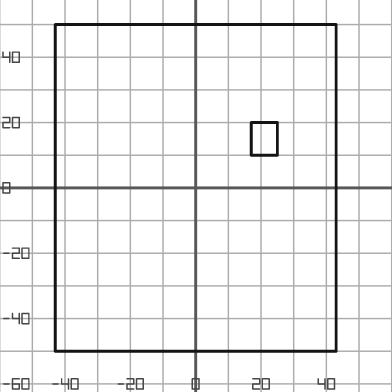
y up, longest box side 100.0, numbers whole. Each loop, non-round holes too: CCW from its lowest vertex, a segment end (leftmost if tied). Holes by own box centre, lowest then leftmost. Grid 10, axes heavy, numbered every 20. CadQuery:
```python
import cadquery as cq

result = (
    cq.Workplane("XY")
    .moveTo(-43.0, -50.0)
    .lineTo(43.0, -50.0)
    .lineTo(43.0, 50.0)
    .lineTo(-43.0, 50.0)
    .close()
    .moveTo(17.0, 10.0)
    .lineTo(25.0, 10.0)
    .lineTo(25.0, 20.0)
    .lineTo(17.0, 20.0)
    .close()
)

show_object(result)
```